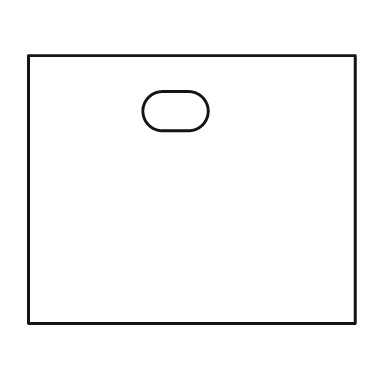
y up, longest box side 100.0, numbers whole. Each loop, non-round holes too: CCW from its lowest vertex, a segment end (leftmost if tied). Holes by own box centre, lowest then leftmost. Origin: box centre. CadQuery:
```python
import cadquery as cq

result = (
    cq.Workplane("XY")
    .moveTo(-50.0, -41.0)
    .lineTo(50.0, -41.0)
    .lineTo(50.0, 41.0)
    .lineTo(-50.0, 41.0)
    .close()
    .moveTo(-9.0, 18.0)
    .lineTo(-1.0, 18.0)
    .threePointArc((5.0, 24.0), (-1.0, 30.0))
    .lineTo(-9.0, 30.0)
    .threePointArc((-15.0, 24.0), (-9.0, 18.0))
    .close()
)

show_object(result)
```